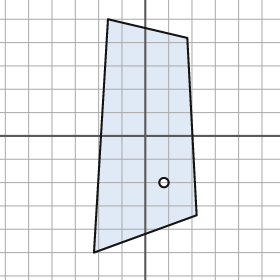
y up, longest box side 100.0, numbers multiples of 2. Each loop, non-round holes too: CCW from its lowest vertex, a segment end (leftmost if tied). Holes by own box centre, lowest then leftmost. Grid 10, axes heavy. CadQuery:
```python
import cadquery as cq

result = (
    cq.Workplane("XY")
    .moveTo(-22.0, -50.0)
    .lineTo(22.0, -34.0)
    .lineTo(18.0, 42.0)
    .lineTo(-16.0, 50.0)
    .close()
    .moveTo(8.0, -20.0)
    .circle(2.0)
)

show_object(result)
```